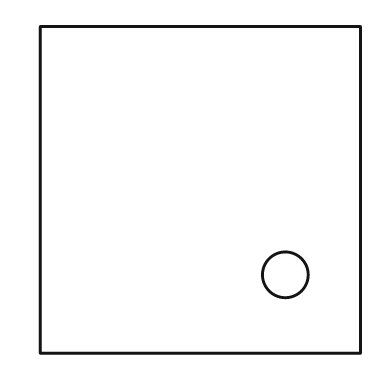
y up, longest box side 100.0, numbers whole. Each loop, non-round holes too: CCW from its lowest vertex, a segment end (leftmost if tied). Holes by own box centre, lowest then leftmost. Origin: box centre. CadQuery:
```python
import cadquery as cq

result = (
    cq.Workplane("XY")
    .moveTo(-49.0, -50.0)
    .lineTo(49.0, -50.0)
    .lineTo(49.0, 50.0)
    .lineTo(-49.0, 50.0)
    .close()
    .moveTo(26.0, -26.0)
    .circle(7.0)
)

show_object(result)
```